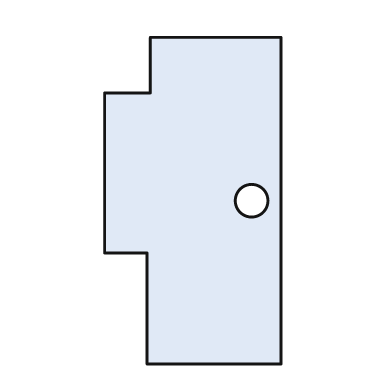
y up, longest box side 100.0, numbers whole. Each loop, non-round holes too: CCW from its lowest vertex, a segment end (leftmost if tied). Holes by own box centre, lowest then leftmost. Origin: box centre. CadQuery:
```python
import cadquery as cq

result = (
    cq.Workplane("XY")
    .moveTo(-14.0, -50.0)
    .lineTo(27.0, -50.0)
    .lineTo(27.0, 50.0)
    .lineTo(-13.0, 50.0)
    .lineTo(-13.0, 33.0)
    .lineTo(-27.0, 33.0)
    .lineTo(-27.0, -16.0)
    .lineTo(-14.0, -16.0)
    .close()
    .moveTo(18.0, 0.0)
    .circle(5.0)
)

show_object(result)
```